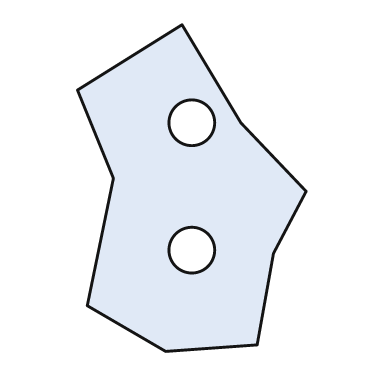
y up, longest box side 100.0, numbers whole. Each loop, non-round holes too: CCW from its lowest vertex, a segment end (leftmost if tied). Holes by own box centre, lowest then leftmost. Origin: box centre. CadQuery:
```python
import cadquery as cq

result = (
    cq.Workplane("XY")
    .moveTo(-8.0, -50.0)
    .lineTo(20.0, -48.0)
    .lineTo(25.0, -20.0)
    .lineTo(35.0, -1.0)
    .lineTo(15.0, 20.0)
    .lineTo(-3.0, 50.0)
    .lineTo(-35.0, 30.0)
    .lineTo(-24.0, 3.0)
    .lineTo(-32.0, -36.0)
    .close()
    .moveTo(0.0, -19.0)
    .circle(7.0)
    .moveTo(0.0, 20.0)
    .circle(7.0)
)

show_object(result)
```